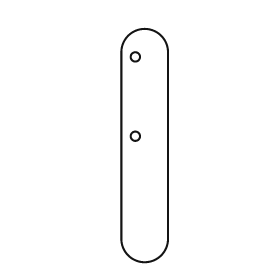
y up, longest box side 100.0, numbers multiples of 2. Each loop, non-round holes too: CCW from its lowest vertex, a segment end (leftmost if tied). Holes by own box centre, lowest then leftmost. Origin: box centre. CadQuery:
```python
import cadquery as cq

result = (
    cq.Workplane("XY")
    .moveTo(-10.0, -40.0)
    .threePointArc((0.0, -50.0), (10.0, -40.0))
    .lineTo(10.0, 40.0)
    .threePointArc((0.0, 50.0), (-10.0, 40.0))
    .close()
    .moveTo(-4.0, 4.0)
    .circle(2.0)
    .moveTo(-4.0, 38.0)
    .circle(2.0)
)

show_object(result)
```